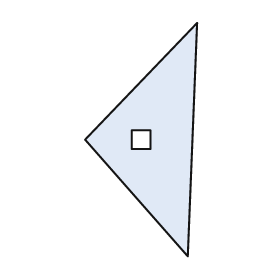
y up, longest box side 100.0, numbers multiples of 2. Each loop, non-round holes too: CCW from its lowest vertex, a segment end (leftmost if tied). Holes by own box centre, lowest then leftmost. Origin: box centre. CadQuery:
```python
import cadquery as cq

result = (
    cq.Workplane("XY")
    .moveTo(20.0, -50.0)
    .lineTo(24.0, 50.0)
    .lineTo(-24.0, 0.0)
    .close()
    .moveTo(-4.0, -4.0)
    .lineTo(4.0, -4.0)
    .lineTo(4.0, 4.0)
    .lineTo(-4.0, 4.0)
    .close()
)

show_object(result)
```